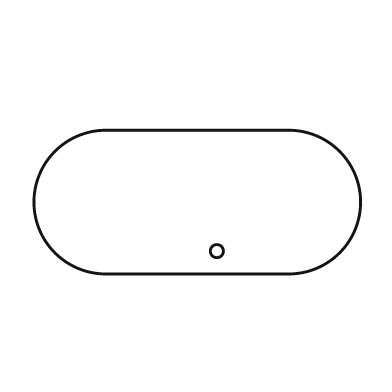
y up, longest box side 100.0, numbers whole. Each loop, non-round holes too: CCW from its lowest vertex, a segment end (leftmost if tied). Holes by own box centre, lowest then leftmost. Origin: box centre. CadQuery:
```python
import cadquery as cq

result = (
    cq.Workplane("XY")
    .moveTo(-28.0, -22.0)
    .lineTo(28.0, -22.0)
    .threePointArc((50.0, 0.0), (28.0, 22.0))
    .lineTo(-28.0, 22.0)
    .threePointArc((-50.0, 0.0), (-28.0, -22.0))
    .close()
    .moveTo(6.0, -15.0)
    .circle(2.0)
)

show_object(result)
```